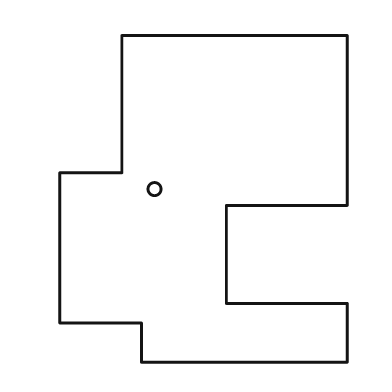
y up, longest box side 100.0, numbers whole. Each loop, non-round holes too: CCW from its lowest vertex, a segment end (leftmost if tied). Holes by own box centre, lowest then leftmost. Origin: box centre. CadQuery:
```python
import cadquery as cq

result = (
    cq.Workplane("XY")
    .moveTo(-19.0, -50.0)
    .lineTo(44.0, -50.0)
    .lineTo(44.0, -32.0)
    .lineTo(7.0, -32.0)
    .lineTo(7.0, -2.0)
    .lineTo(44.0, -2.0)
    .lineTo(44.0, 50.0)
    .lineTo(-25.0, 50.0)
    .lineTo(-25.0, 8.0)
    .lineTo(-44.0, 8.0)
    .lineTo(-44.0, -38.0)
    .lineTo(-19.0, -38.0)
    .close()
    .moveTo(-15.0, 3.0)
    .circle(2.0)
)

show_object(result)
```